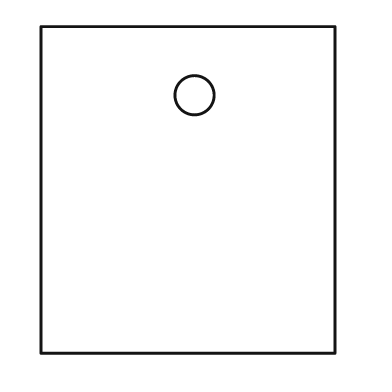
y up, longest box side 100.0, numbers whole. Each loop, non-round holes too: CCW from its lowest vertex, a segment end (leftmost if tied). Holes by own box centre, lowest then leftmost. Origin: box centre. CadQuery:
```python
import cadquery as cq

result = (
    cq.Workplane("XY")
    .moveTo(-45.0, -50.0)
    .lineTo(45.0, -50.0)
    .lineTo(45.0, 50.0)
    .lineTo(-45.0, 50.0)
    .close()
    .moveTo(2.0, 29.0)
    .circle(6.0)
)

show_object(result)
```